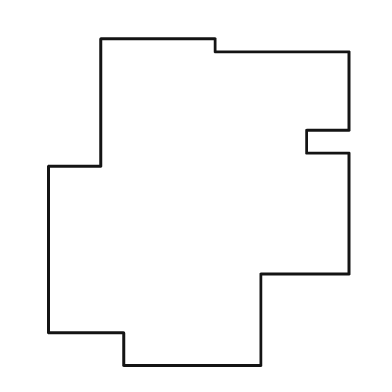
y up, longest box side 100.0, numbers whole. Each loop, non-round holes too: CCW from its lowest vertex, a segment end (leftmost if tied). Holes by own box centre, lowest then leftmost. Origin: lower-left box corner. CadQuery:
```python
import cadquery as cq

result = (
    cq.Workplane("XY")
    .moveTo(23.0, 0.0)
    .lineTo(65.0, 0.0)
    .lineTo(65.0, 28.0)
    .lineTo(92.0, 28.0)
    .lineTo(92.0, 65.0)
    .lineTo(79.0, 65.0)
    .lineTo(79.0, 72.0)
    .lineTo(92.0, 72.0)
    .lineTo(92.0, 96.0)
    .lineTo(51.0, 96.0)
    .lineTo(51.0, 100.0)
    .lineTo(16.0, 100.0)
    .lineTo(16.0, 61.0)
    .lineTo(0.0, 61.0)
    .lineTo(0.0, 10.0)
    .lineTo(23.0, 10.0)
    .close()
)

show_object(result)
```